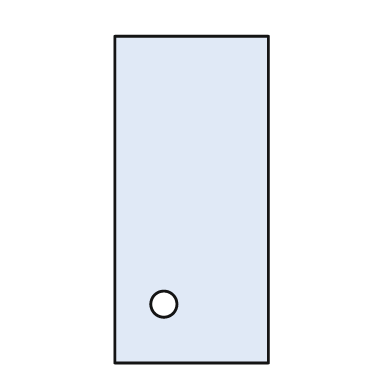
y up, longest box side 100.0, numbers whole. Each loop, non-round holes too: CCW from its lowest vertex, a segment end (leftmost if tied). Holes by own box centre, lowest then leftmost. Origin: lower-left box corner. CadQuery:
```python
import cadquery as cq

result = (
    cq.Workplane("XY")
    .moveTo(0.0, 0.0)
    .lineTo(47.0, 0.0)
    .lineTo(47.0, 100.0)
    .lineTo(0.0, 100.0)
    .close()
    .moveTo(15.0, 18.0)
    .circle(4.0)
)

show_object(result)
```